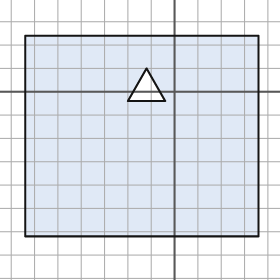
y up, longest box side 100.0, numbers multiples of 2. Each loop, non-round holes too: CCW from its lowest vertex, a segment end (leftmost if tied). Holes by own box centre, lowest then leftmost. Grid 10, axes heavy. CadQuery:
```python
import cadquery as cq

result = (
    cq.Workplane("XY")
    .moveTo(-64.0, -62.0)
    .lineTo(36.0, -62.0)
    .lineTo(36.0, 24.0)
    .lineTo(-64.0, 24.0)
    .close()
    .moveTo(-20.0, -4.0)
    .lineTo(-4.0, -4.0)
    .lineTo(-12.0, 10.0)
    .close()
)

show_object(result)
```